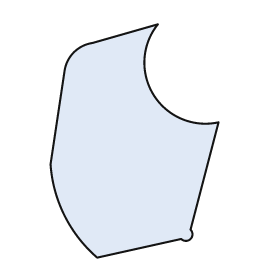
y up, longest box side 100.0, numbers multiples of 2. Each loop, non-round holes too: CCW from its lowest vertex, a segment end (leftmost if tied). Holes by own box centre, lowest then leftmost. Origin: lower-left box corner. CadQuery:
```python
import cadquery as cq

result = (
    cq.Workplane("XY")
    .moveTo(20.0, 0.0)
    .lineTo(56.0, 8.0)
    .threePointArc((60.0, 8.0), (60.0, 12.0))
    .lineTo(72.0, 58.0)
    .threePointArc((44.0, 70.0), (46.0, 100.0))
    .lineTo(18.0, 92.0)
    .threePointArc((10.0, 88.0), (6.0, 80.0))
    .lineTo(0.0, 40.0)
    .threePointArc((6.0, 18.0), (20.0, 0.0))
    .close()
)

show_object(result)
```